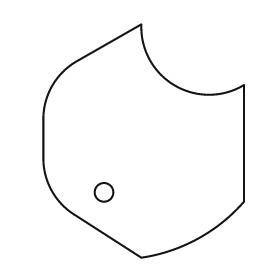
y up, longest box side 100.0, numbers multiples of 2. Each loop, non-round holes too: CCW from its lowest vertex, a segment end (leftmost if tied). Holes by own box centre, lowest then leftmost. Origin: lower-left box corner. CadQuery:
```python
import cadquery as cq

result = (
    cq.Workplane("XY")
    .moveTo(42.0, 0.0)
    .threePointArc((66.0, 8.0), (86.0, 24.0))
    .lineTo(86.0, 74.0)
    .threePointArc((56.0, 74.0), (42.0, 100.0))
    .lineTo(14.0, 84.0)
    .threePointArc((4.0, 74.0), (0.0, 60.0))
    .lineTo(0.0, 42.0)
    .threePointArc((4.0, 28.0), (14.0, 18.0))
    .close()
    .moveTo(26.0, 28.0)
    .circle(4.0)
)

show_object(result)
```